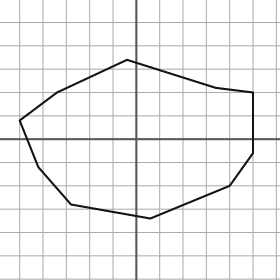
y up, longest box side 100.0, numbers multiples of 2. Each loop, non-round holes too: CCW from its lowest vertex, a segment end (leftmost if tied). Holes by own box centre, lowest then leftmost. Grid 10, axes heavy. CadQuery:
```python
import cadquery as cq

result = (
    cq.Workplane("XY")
    .moveTo(6.0, -34.0)
    .lineTo(40.0, -20.0)
    .lineTo(50.0, -6.0)
    .lineTo(50.0, 20.0)
    .lineTo(34.0, 22.0)
    .lineTo(-4.0, 34.0)
    .lineTo(-34.0, 20.0)
    .lineTo(-50.0, 8.0)
    .lineTo(-42.0, -12.0)
    .lineTo(-28.0, -28.0)
    .close()
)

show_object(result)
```